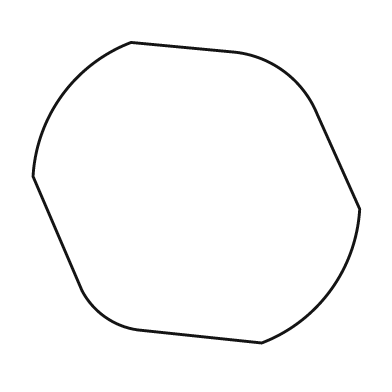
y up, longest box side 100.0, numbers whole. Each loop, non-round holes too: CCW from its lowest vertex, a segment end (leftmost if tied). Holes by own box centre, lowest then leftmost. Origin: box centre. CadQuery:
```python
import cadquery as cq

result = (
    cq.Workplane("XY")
    .moveTo(20.0, -46.0)
    .threePointArc((41.0, -30.0), (50.0, -5.0))
    .lineTo(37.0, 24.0)
    .threePointArc((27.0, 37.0), (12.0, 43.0))
    .lineTo(-20.0, 46.0)
    .threePointArc((-41.0, 30.0), (-50.0, 5.0))
    .lineTo(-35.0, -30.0)
    .threePointArc((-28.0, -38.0), (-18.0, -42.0))
    .close()
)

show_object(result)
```